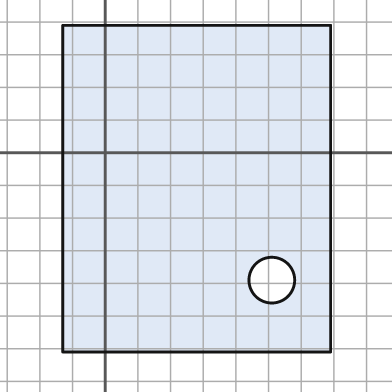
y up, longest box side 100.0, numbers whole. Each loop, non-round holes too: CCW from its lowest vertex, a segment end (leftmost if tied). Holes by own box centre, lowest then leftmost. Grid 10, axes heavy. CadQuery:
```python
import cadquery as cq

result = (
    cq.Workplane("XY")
    .moveTo(-13.0, -61.0)
    .lineTo(69.0, -61.0)
    .lineTo(69.0, 39.0)
    .lineTo(-13.0, 39.0)
    .close()
    .moveTo(51.0, -39.0)
    .circle(7.0)
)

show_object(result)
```